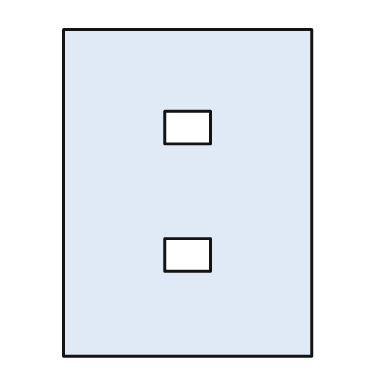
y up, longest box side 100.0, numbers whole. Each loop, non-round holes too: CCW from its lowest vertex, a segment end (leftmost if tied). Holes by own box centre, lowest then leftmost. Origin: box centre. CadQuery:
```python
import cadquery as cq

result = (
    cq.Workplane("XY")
    .moveTo(-38.0, -50.0)
    .lineTo(38.0, -50.0)
    .lineTo(38.0, 50.0)
    .lineTo(-38.0, 50.0)
    .close()
    .moveTo(-7.0, -24.0)
    .lineTo(7.0, -24.0)
    .lineTo(7.0, -14.0)
    .lineTo(-7.0, -14.0)
    .close()
    .moveTo(-7.0, 15.0)
    .lineTo(7.0, 15.0)
    .lineTo(7.0, 25.0)
    .lineTo(-7.0, 25.0)
    .close()
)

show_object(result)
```